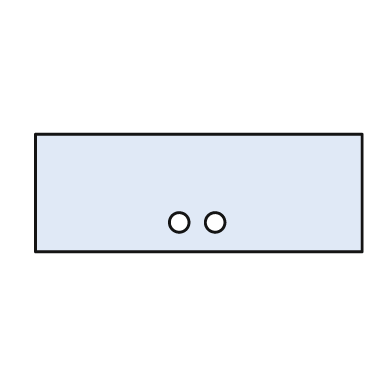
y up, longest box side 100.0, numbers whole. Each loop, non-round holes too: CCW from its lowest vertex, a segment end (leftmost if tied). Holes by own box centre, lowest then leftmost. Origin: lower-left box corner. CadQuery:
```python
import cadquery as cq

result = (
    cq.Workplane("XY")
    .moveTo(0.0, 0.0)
    .lineTo(100.0, 0.0)
    .lineTo(100.0, 36.0)
    .lineTo(0.0, 36.0)
    .close()
    .moveTo(44.0, 9.0)
    .circle(3.0)
    .moveTo(55.0, 9.0)
    .circle(3.0)
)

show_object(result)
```